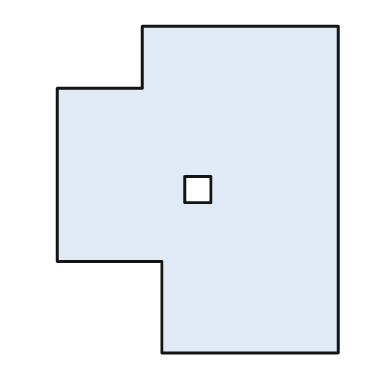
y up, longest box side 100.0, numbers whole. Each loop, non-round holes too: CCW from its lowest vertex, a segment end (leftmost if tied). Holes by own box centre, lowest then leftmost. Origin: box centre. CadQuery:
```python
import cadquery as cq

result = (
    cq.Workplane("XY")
    .moveTo(-11.0, -50.0)
    .lineTo(43.0, -50.0)
    .lineTo(43.0, 50.0)
    .lineTo(-17.0, 50.0)
    .lineTo(-17.0, 31.0)
    .lineTo(-43.0, 31.0)
    .lineTo(-43.0, -22.0)
    .lineTo(-11.0, -22.0)
    .close()
    .moveTo(-4.0, -4.0)
    .lineTo(4.0, -4.0)
    .lineTo(4.0, 4.0)
    .lineTo(-4.0, 4.0)
    .close()
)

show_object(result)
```